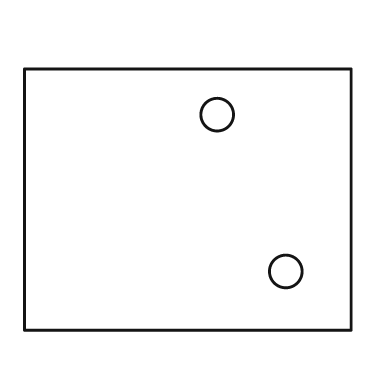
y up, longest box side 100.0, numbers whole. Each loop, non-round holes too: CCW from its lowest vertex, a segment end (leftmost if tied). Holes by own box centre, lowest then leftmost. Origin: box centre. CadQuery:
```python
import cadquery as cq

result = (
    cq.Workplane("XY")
    .moveTo(-50.0, -40.0)
    .lineTo(50.0, -40.0)
    .lineTo(50.0, 40.0)
    .lineTo(-50.0, 40.0)
    .close()
    .moveTo(30.0, -22.0)
    .circle(5.0)
    .moveTo(9.0, 26.0)
    .circle(5.0)
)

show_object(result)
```